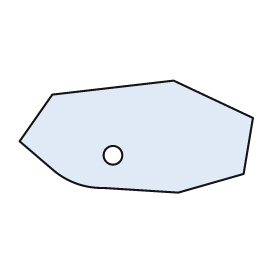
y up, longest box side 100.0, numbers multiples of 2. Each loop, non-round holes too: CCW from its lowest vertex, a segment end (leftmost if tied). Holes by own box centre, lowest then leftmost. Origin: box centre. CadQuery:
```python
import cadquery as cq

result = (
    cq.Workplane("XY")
    .moveTo(18.0, -24.0)
    .lineTo(46.0, -16.0)
    .lineTo(50.0, 8.0)
    .lineTo(16.0, 24.0)
    .lineTo(-36.0, 18.0)
    .lineTo(-50.0, -2.0)
    .lineTo(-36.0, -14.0)
    .threePointArc((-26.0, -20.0), (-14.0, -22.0))
    .close()
    .moveTo(-10.0, -8.0)
    .circle(4.0)
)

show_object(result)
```